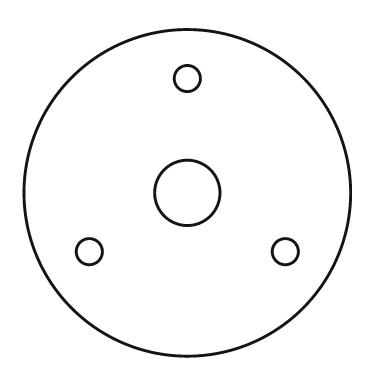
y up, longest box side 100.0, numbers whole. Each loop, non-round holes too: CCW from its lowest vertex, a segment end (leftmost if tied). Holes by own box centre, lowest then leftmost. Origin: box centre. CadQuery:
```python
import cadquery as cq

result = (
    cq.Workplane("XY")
    .moveTo(0.0, 0.0)
    .circle(50.0)
    .moveTo(-30.0, -18.0)
    .circle(4.0)
    .moveTo(30.0, -18.0)
    .circle(4.0)
    .moveTo(0.0, 0.0)
    .circle(10.0)
    .moveTo(0.0, 35.0)
    .circle(4.0)
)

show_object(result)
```